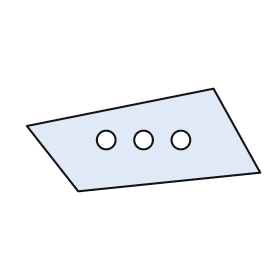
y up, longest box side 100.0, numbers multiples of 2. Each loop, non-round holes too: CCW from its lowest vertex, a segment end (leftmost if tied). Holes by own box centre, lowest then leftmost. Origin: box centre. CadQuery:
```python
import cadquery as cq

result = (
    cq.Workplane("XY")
    .moveTo(-28.0, -22.0)
    .lineTo(50.0, -14.0)
    .lineTo(30.0, 22.0)
    .lineTo(-50.0, 6.0)
    .close()
    .moveTo(-16.0, 0.0)
    .circle(4.0)
    .moveTo(0.0, 0.0)
    .circle(4.0)
    .moveTo(16.0, 0.0)
    .circle(4.0)
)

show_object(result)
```